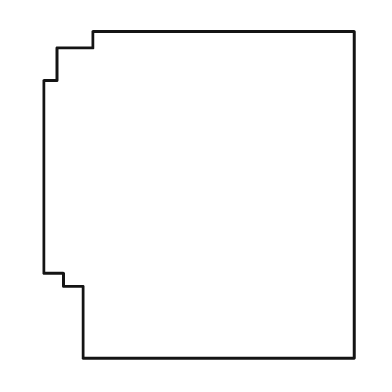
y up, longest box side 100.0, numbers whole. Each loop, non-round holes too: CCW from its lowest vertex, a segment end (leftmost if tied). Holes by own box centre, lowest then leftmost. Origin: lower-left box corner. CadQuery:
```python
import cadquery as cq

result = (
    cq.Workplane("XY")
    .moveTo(12.0, 0.0)
    .lineTo(95.0, 0.0)
    .lineTo(95.0, 100.0)
    .lineTo(15.0, 100.0)
    .lineTo(15.0, 95.0)
    .lineTo(4.0, 95.0)
    .lineTo(4.0, 85.0)
    .lineTo(0.0, 85.0)
    .lineTo(0.0, 26.0)
    .lineTo(6.0, 26.0)
    .lineTo(6.0, 22.0)
    .lineTo(12.0, 22.0)
    .close()
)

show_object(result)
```